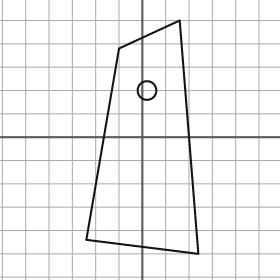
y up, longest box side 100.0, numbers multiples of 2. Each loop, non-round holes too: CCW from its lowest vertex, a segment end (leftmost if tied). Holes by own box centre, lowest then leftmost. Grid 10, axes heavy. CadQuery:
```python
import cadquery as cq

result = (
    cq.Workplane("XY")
    .moveTo(24.0, -50.0)
    .lineTo(16.0, 50.0)
    .lineTo(-10.0, 38.0)
    .lineTo(-24.0, -44.0)
    .close()
    .moveTo(2.0, 20.0)
    .circle(4.0)
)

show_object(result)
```